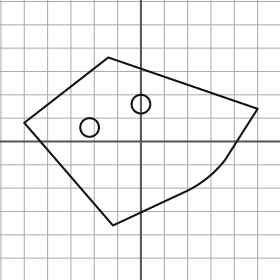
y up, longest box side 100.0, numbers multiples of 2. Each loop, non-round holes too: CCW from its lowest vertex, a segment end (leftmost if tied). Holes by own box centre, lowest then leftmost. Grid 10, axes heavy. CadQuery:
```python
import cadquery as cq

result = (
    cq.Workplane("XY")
    .moveTo(-12.0, -36.0)
    .lineTo(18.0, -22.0)
    .threePointArc((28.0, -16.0), (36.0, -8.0))
    .lineTo(50.0, 14.0)
    .lineTo(-14.0, 36.0)
    .lineTo(-50.0, 8.0)
    .close()
    .moveTo(-22.0, 6.0)
    .circle(4.0)
    .moveTo(0.0, 16.0)
    .circle(4.0)
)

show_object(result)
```